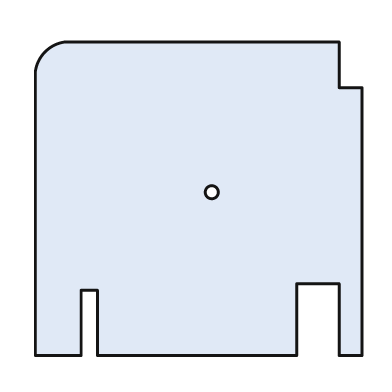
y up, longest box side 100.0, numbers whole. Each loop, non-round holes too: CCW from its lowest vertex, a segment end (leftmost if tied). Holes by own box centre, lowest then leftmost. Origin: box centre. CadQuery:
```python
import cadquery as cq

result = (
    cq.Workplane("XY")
    .moveTo(-50.0, -48.0)
    .lineTo(-36.0, -48.0)
    .lineTo(-36.0, -28.0)
    .lineTo(-31.0, -28.0)
    .lineTo(-31.0, -48.0)
    .lineTo(30.0, -48.0)
    .lineTo(30.0, -26.0)
    .lineTo(43.0, -26.0)
    .lineTo(43.0, -48.0)
    .lineTo(50.0, -48.0)
    .lineTo(50.0, 34.0)
    .lineTo(43.0, 34.0)
    .lineTo(43.0, 48.0)
    .lineTo(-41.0, 48.0)
    .threePointArc((-47.0, 45.0), (-50.0, 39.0))
    .close()
    .moveTo(4.0, 2.0)
    .circle(2.0)
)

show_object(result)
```